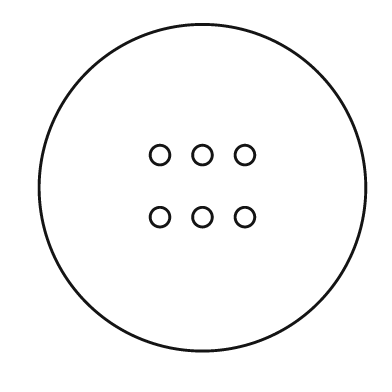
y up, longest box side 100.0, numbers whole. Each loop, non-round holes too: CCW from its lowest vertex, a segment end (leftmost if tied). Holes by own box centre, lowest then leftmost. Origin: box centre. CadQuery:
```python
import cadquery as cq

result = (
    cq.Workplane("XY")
    .moveTo(0.0, 0.0)
    .circle(50.0)
    .moveTo(-13.0, -9.0)
    .circle(3.0)
    .moveTo(0.0, -9.0)
    .circle(3.0)
    .moveTo(13.0, -9.0)
    .circle(3.0)
    .moveTo(-13.0, 10.0)
    .circle(3.0)
    .moveTo(0.0, 10.0)
    .circle(3.0)
    .moveTo(13.0, 10.0)
    .circle(3.0)
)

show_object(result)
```